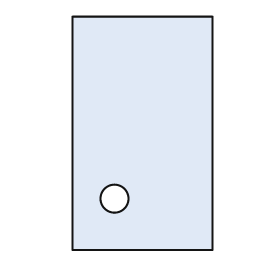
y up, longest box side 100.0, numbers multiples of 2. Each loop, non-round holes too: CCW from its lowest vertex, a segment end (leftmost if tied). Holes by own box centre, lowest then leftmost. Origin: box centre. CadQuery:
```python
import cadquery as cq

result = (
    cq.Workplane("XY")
    .moveTo(-30.0, -50.0)
    .lineTo(30.0, -50.0)
    .lineTo(30.0, 50.0)
    .lineTo(-30.0, 50.0)
    .close()
    .moveTo(-12.0, -28.0)
    .circle(6.0)
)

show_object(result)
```